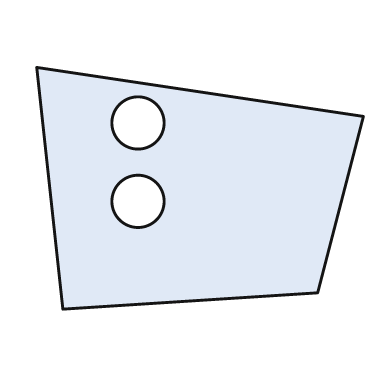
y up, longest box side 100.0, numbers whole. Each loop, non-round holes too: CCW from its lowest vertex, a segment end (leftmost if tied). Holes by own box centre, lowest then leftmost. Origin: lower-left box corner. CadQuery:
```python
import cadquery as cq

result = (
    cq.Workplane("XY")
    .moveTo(8.0, 0.0)
    .lineTo(86.0, 5.0)
    .lineTo(100.0, 59.0)
    .lineTo(0.0, 74.0)
    .close()
    .moveTo(31.0, 33.0)
    .circle(8.0)
    .moveTo(31.0, 57.0)
    .circle(8.0)
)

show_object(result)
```